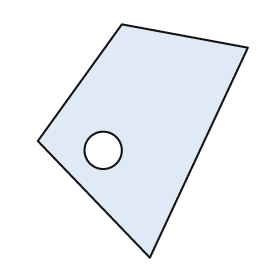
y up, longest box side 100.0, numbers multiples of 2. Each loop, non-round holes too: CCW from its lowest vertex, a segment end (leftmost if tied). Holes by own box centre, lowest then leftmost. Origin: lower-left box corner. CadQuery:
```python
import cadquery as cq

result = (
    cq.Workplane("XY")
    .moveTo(48.0, 0.0)
    .lineTo(90.0, 90.0)
    .lineTo(36.0, 100.0)
    .lineTo(0.0, 50.0)
    .close()
    .moveTo(28.0, 46.0)
    .circle(8.0)
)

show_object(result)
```